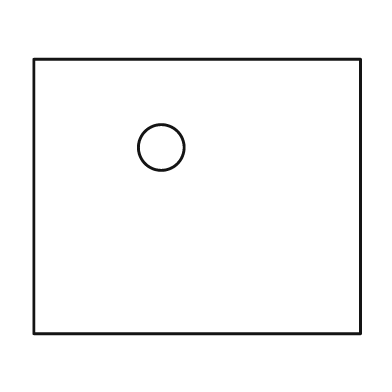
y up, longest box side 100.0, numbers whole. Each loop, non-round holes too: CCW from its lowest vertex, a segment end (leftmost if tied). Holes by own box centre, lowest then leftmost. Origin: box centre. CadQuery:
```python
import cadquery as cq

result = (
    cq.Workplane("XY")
    .moveTo(-50.0, -42.0)
    .lineTo(50.0, -42.0)
    .lineTo(50.0, 42.0)
    .lineTo(-50.0, 42.0)
    .close()
    .moveTo(-11.0, 15.0)
    .circle(7.0)
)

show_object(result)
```